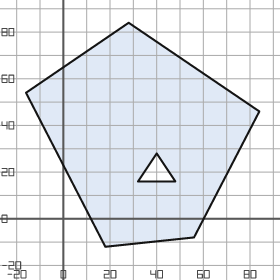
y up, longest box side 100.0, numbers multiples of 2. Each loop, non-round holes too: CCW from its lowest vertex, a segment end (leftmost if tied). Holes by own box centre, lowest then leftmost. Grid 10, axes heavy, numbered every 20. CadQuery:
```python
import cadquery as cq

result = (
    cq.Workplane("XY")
    .moveTo(18.0, -12.0)
    .lineTo(56.0, -8.0)
    .lineTo(84.0, 46.0)
    .lineTo(28.0, 84.0)
    .lineTo(-16.0, 54.0)
    .close()
    .moveTo(32.0, 16.0)
    .lineTo(48.0, 16.0)
    .lineTo(40.0, 28.0)
    .close()
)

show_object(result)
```